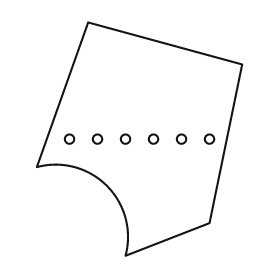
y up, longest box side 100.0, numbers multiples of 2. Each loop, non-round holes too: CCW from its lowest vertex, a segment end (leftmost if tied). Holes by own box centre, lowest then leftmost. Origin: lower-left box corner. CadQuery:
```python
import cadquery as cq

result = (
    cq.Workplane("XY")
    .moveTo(38.0, 0.0)
    .lineTo(74.0, 14.0)
    .lineTo(88.0, 82.0)
    .lineTo(22.0, 100.0)
    .lineTo(0.0, 38.0)
    .threePointArc((30.0, 30.0), (38.0, 0.0))
    .close()
    .moveTo(14.0, 50.0)
    .circle(2.0)
    .moveTo(26.0, 50.0)
    .circle(2.0)
    .moveTo(38.0, 50.0)
    .circle(2.0)
    .moveTo(50.0, 50.0)
    .circle(2.0)
    .moveTo(62.0, 50.0)
    .circle(2.0)
    .moveTo(74.0, 50.0)
    .circle(2.0)
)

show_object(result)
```